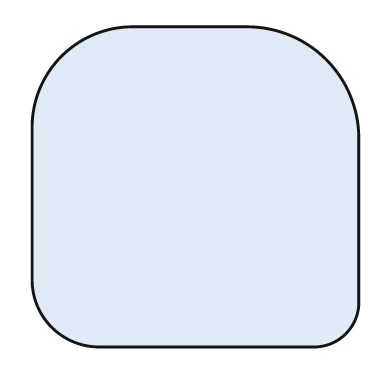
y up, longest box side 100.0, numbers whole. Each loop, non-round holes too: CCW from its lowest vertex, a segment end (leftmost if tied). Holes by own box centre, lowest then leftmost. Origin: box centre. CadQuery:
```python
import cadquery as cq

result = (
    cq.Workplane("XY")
    .moveTo(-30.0, -49.0)
    .lineTo(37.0, -49.0)
    .threePointArc((46.0, -45.0), (50.0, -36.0))
    .lineTo(50.0, 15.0)
    .threePointArc((40.0, 39.0), (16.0, 49.0))
    .lineTo(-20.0, 49.0)
    .threePointArc((-41.0, 40.0), (-50.0, 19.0))
    .lineTo(-50.0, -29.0)
    .threePointArc((-44.0, -43.0), (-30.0, -49.0))
    .close()
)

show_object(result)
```